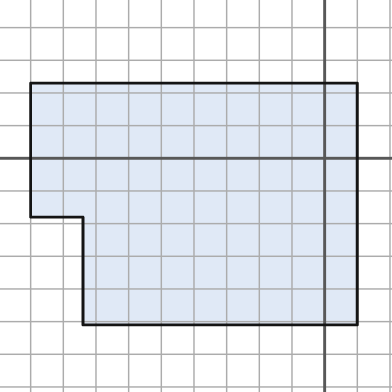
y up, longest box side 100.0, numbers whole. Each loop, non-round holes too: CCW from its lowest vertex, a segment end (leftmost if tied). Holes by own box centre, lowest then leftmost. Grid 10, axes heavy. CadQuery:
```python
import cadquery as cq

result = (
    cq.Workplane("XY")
    .moveTo(-74.0, -51.0)
    .lineTo(10.0, -51.0)
    .lineTo(10.0, 23.0)
    .lineTo(-90.0, 23.0)
    .lineTo(-90.0, -18.0)
    .lineTo(-74.0, -18.0)
    .close()
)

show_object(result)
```